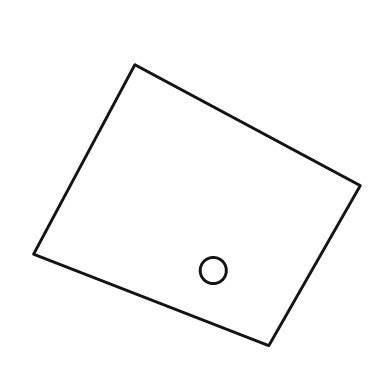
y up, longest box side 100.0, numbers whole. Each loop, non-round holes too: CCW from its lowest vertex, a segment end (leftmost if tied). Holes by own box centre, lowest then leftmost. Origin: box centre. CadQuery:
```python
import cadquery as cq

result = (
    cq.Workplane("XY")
    .moveTo(22.0, -43.0)
    .lineTo(50.0, 6.0)
    .lineTo(-19.0, 43.0)
    .lineTo(-50.0, -15.0)
    .close()
    .moveTo(5.0, -20.0)
    .circle(4.0)
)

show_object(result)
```